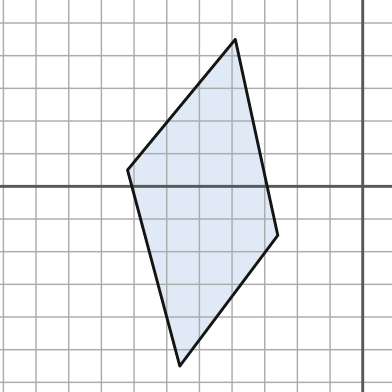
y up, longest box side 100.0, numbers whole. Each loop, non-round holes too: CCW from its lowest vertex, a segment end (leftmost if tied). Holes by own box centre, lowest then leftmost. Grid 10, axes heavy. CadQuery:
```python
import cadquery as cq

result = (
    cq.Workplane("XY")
    .moveTo(-56.0, -55.0)
    .lineTo(-26.0, -15.0)
    .lineTo(-39.0, 45.0)
    .lineTo(-72.0, 5.0)
    .close()
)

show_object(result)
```